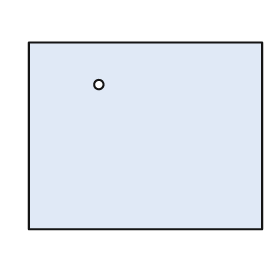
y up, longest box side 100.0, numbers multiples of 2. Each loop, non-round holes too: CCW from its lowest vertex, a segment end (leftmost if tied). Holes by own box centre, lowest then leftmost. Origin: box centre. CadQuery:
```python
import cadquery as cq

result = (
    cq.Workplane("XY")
    .moveTo(-50.0, -40.0)
    .lineTo(50.0, -40.0)
    .lineTo(50.0, 40.0)
    .lineTo(-50.0, 40.0)
    .close()
    .moveTo(-20.0, 22.0)
    .circle(2.0)
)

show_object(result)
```